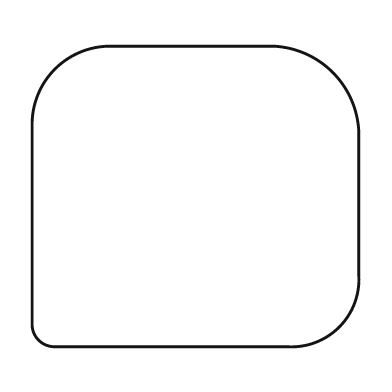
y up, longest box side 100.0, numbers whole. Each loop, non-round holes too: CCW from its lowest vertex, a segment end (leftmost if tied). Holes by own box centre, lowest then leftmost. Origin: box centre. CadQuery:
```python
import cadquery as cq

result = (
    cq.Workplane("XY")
    .moveTo(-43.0, -46.0)
    .lineTo(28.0, -46.0)
    .threePointArc((44.0, -40.0), (50.0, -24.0))
    .lineTo(50.0, 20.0)
    .threePointArc((42.0, 38.0), (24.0, 46.0))
    .lineTo(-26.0, 46.0)
    .threePointArc((-43.0, 39.0), (-50.0, 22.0))
    .lineTo(-50.0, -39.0)
    .threePointArc((-48.0, -44.0), (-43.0, -46.0))
    .close()
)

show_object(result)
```